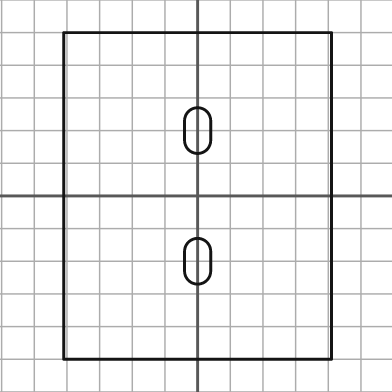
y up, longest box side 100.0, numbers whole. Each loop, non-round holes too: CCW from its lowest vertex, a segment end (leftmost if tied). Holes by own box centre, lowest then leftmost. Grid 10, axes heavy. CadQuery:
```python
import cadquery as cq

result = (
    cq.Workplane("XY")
    .moveTo(-41.0, -50.0)
    .lineTo(41.0, -50.0)
    .lineTo(41.0, 50.0)
    .lineTo(-41.0, 50.0)
    .close()
    .moveTo(-4.0, -23.0)
    .threePointArc((0.0, -27.0), (4.0, -23.0))
    .lineTo(4.0, -17.0)
    .threePointArc((0.0, -13.0), (-4.0, -17.0))
    .close()
    .moveTo(-4.0, 17.0)
    .threePointArc((0.0, 13.0), (4.0, 17.0))
    .lineTo(4.0, 23.0)
    .threePointArc((0.0, 27.0), (-4.0, 23.0))
    .close()
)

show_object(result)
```